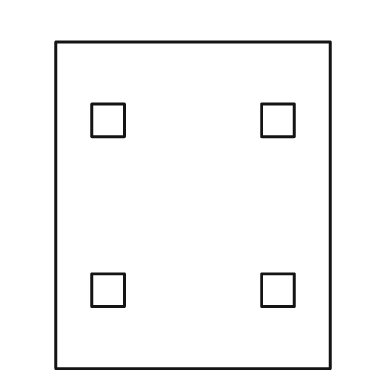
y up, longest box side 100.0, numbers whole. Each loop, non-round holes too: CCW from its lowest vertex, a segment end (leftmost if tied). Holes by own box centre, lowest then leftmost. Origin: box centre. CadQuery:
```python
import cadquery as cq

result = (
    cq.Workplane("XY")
    .moveTo(-42.0, -50.0)
    .lineTo(42.0, -50.0)
    .lineTo(42.0, 50.0)
    .lineTo(-42.0, 50.0)
    .close()
    .moveTo(-31.0, -31.0)
    .lineTo(-21.0, -31.0)
    .lineTo(-21.0, -21.0)
    .lineTo(-31.0, -21.0)
    .close()
    .moveTo(21.0, -31.0)
    .lineTo(31.0, -31.0)
    .lineTo(31.0, -21.0)
    .lineTo(21.0, -21.0)
    .close()
    .moveTo(-31.0, 21.0)
    .lineTo(-21.0, 21.0)
    .lineTo(-21.0, 31.0)
    .lineTo(-31.0, 31.0)
    .close()
    .moveTo(21.0, 21.0)
    .lineTo(31.0, 21.0)
    .lineTo(31.0, 31.0)
    .lineTo(21.0, 31.0)
    .close()
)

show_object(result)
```